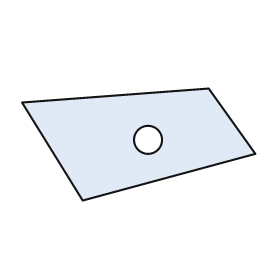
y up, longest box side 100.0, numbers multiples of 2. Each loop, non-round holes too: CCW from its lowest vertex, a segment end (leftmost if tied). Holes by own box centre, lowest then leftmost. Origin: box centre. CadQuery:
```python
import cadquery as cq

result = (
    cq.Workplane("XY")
    .moveTo(-24.0, -24.0)
    .lineTo(50.0, -4.0)
    .lineTo(30.0, 24.0)
    .lineTo(-50.0, 18.0)
    .close()
    .moveTo(4.0, 2.0)
    .circle(6.0)
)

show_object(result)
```